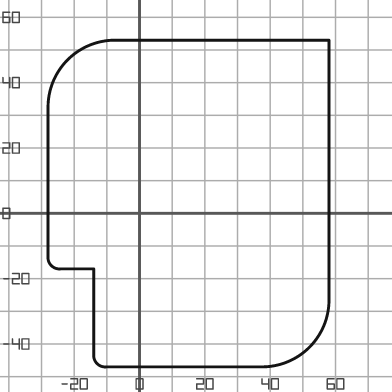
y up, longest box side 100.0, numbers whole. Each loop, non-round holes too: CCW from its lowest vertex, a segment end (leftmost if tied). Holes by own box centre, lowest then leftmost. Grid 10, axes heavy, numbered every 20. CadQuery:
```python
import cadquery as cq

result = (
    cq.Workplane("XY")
    .moveTo(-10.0, -47.0)
    .lineTo(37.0, -47.0)
    .threePointArc((52.0, -41.0), (58.0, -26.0))
    .lineTo(58.0, 53.0)
    .lineTo(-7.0, 53.0)
    .threePointArc((-22.0, 47.0), (-28.0, 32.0))
    .lineTo(-28.0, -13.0)
    .threePointArc((-27.0, -16.0), (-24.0, -17.0))
    .lineTo(-14.0, -17.0)
    .lineTo(-14.0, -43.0)
    .threePointArc((-13.0, -46.0), (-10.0, -47.0))
    .close()
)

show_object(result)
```